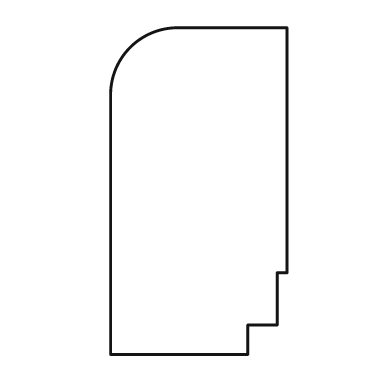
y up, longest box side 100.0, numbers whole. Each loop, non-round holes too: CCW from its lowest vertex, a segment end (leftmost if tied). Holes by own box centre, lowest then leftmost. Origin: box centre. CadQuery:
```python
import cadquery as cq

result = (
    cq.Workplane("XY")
    .moveTo(-27.0, -50.0)
    .lineTo(15.0, -50.0)
    .lineTo(15.0, -41.0)
    .lineTo(24.0, -41.0)
    .lineTo(24.0, -25.0)
    .lineTo(27.0, -25.0)
    .lineTo(27.0, 50.0)
    .lineTo(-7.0, 50.0)
    .threePointArc((-21.0, 44.0), (-27.0, 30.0))
    .close()
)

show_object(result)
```